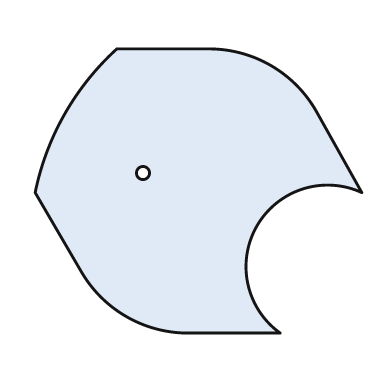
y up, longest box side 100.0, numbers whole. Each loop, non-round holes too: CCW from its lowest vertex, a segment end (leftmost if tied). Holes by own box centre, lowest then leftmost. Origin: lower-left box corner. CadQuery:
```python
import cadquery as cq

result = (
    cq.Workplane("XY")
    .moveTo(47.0, 0.0)
    .lineTo(75.0, 0.0)
    .threePointArc((68.0, 33.0), (100.0, 43.0))
    .lineTo(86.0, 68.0)
    .threePointArc((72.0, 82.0), (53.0, 87.0))
    .lineTo(25.0, 87.0)
    .threePointArc((9.0, 67.0), (0.0, 43.0))
    .lineTo(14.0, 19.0)
    .threePointArc((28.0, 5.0), (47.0, 0.0))
    .close()
    .moveTo(33.0, 49.0)
    .circle(2.0)
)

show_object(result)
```